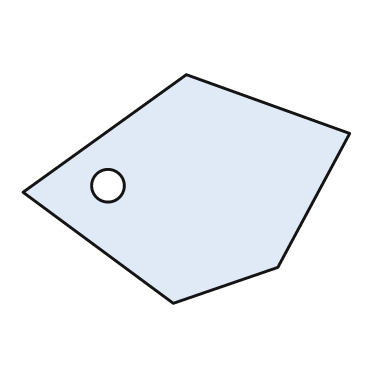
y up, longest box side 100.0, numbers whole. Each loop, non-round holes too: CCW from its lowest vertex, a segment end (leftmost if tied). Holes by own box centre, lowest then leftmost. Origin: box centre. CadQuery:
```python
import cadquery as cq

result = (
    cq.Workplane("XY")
    .moveTo(-4.0, -35.0)
    .lineTo(28.0, -24.0)
    .lineTo(50.0, 17.0)
    .lineTo(0.0, 35.0)
    .lineTo(-50.0, -1.0)
    .close()
    .moveTo(-24.0, 1.0)
    .circle(5.0)
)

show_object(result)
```